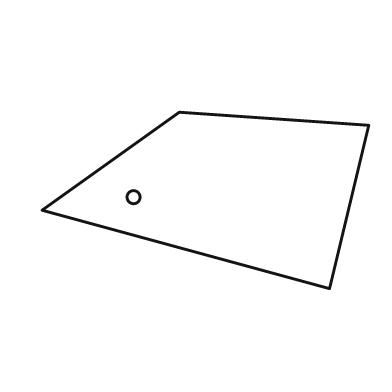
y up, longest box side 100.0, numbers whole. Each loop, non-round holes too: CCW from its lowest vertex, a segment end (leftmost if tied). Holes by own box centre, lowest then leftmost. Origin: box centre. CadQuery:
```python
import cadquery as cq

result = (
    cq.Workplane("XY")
    .moveTo(38.0, -27.0)
    .lineTo(50.0, 23.0)
    .lineTo(-8.0, 27.0)
    .lineTo(-50.0, -3.0)
    .close()
    .moveTo(-22.0, 1.0)
    .circle(2.0)
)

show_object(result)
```